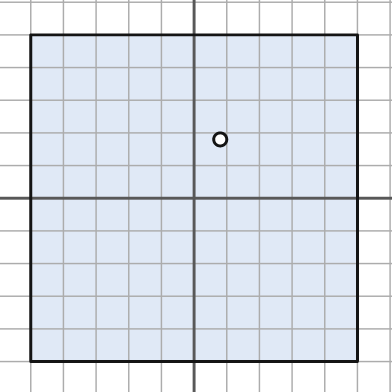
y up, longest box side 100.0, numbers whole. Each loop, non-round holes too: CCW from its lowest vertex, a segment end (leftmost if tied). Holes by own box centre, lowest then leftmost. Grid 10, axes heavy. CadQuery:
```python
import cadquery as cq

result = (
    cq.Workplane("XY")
    .moveTo(-50.0, -50.0)
    .lineTo(50.0, -50.0)
    .lineTo(50.0, 50.0)
    .lineTo(-50.0, 50.0)
    .close()
    .moveTo(8.0, 18.0)
    .circle(2.0)
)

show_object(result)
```